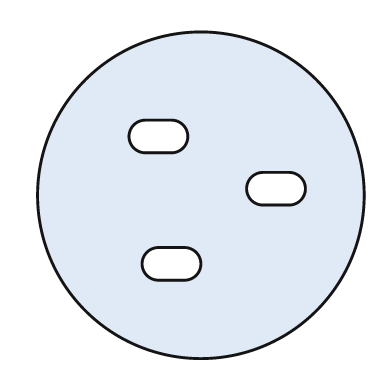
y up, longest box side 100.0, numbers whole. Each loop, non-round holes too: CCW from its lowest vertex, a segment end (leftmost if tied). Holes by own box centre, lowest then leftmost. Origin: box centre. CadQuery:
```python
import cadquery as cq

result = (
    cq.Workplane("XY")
    .moveTo(0.0, 0.0)
    .circle(50.0)
    .moveTo(-13.0, -26.0)
    .lineTo(-5.0, -26.0)
    .threePointArc((0.0, -21.0), (-5.0, -16.0))
    .lineTo(-13.0, -16.0)
    .threePointArc((-18.0, -21.0), (-13.0, -26.0))
    .close()
    .moveTo(19.0, -3.0)
    .lineTo(27.0, -3.0)
    .threePointArc((32.0, 2.0), (27.0, 7.0))
    .lineTo(19.0, 7.0)
    .threePointArc((14.0, 2.0), (19.0, -3.0))
    .close()
    .moveTo(-17.0, 13.0)
    .lineTo(-9.0, 13.0)
    .threePointArc((-4.0, 18.0), (-9.0, 23.0))
    .lineTo(-17.0, 23.0)
    .threePointArc((-22.0, 18.0), (-17.0, 13.0))
    .close()
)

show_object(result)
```